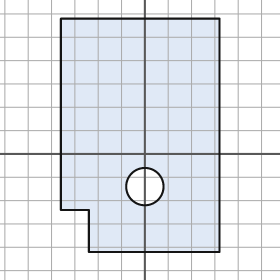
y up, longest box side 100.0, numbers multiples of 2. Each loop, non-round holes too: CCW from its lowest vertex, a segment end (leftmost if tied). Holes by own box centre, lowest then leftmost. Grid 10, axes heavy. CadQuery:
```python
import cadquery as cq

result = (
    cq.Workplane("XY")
    .moveTo(-24.0, -42.0)
    .lineTo(32.0, -42.0)
    .lineTo(32.0, 58.0)
    .lineTo(-36.0, 58.0)
    .lineTo(-36.0, -24.0)
    .lineTo(-24.0, -24.0)
    .close()
    .moveTo(0.0, -14.0)
    .circle(8.0)
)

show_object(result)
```